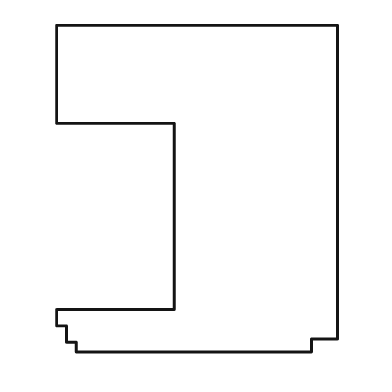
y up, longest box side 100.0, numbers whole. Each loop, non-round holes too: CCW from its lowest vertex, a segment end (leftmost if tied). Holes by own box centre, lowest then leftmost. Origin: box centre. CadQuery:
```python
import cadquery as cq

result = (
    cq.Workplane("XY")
    .moveTo(-37.0, -50.0)
    .lineTo(35.0, -50.0)
    .lineTo(35.0, -46.0)
    .lineTo(43.0, -46.0)
    .lineTo(43.0, 50.0)
    .lineTo(-43.0, 50.0)
    .lineTo(-43.0, 20.0)
    .lineTo(-7.0, 20.0)
    .lineTo(-7.0, -37.0)
    .lineTo(-43.0, -37.0)
    .lineTo(-43.0, -42.0)
    .lineTo(-40.0, -42.0)
    .lineTo(-40.0, -47.0)
    .lineTo(-37.0, -47.0)
    .close()
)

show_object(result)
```